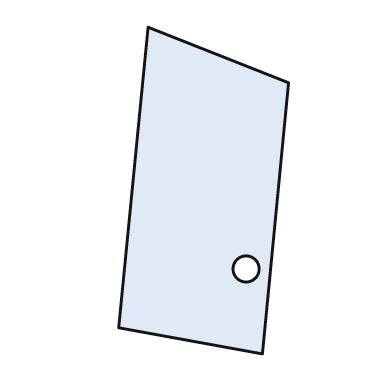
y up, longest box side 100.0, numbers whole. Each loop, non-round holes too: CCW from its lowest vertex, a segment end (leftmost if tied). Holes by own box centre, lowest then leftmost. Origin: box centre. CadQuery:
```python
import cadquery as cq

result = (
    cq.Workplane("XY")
    .moveTo(18.0, -50.0)
    .lineTo(26.0, 33.0)
    .lineTo(-17.0, 50.0)
    .lineTo(-26.0, -42.0)
    .close()
    .moveTo(13.0, -24.0)
    .circle(4.0)
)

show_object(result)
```